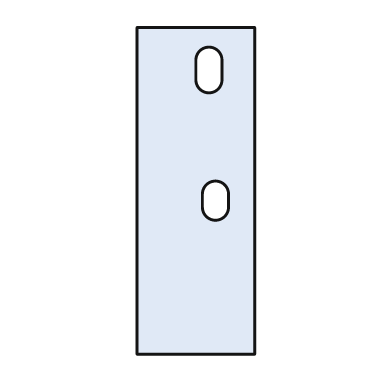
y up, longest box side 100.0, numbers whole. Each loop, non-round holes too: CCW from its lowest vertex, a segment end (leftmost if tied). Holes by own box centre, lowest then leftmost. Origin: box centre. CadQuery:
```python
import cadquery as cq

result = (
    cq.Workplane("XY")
    .moveTo(-18.0, -50.0)
    .lineTo(18.0, -50.0)
    .lineTo(18.0, 50.0)
    .lineTo(-18.0, 50.0)
    .close()
    .moveTo(2.0, -5.0)
    .threePointArc((6.0, -9.0), (10.0, -5.0))
    .lineTo(10.0, -1.0)
    .threePointArc((6.0, 3.0), (2.0, -1.0))
    .close()
    .moveTo(0.0, 34.0)
    .threePointArc((4.0, 30.0), (8.0, 34.0))
    .lineTo(8.0, 40.0)
    .threePointArc((4.0, 44.0), (0.0, 40.0))
    .close()
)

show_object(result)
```